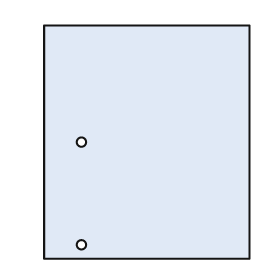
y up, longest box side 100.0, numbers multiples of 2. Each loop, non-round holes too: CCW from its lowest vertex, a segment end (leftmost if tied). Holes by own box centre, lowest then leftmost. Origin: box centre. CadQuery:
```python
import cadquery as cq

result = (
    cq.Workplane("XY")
    .moveTo(-44.0, -50.0)
    .lineTo(44.0, -50.0)
    .lineTo(44.0, 50.0)
    .lineTo(-44.0, 50.0)
    .close()
    .moveTo(-28.0, -44.0)
    .circle(2.0)
    .moveTo(-28.0, 0.0)
    .circle(2.0)
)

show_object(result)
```